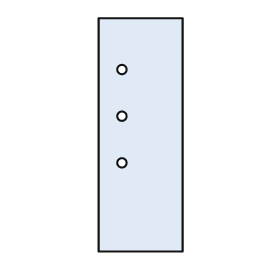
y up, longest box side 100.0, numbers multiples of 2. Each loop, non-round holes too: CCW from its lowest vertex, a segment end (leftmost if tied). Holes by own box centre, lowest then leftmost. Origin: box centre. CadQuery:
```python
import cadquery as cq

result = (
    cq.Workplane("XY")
    .moveTo(-18.0, -50.0)
    .lineTo(18.0, -50.0)
    .lineTo(18.0, 50.0)
    .lineTo(-18.0, 50.0)
    .close()
    .moveTo(-8.0, -12.0)
    .circle(2.0)
    .moveTo(-8.0, 8.0)
    .circle(2.0)
    .moveTo(-8.0, 28.0)
    .circle(2.0)
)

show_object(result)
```